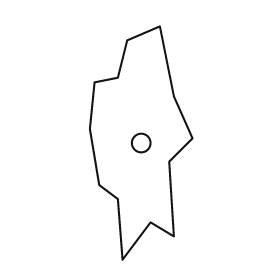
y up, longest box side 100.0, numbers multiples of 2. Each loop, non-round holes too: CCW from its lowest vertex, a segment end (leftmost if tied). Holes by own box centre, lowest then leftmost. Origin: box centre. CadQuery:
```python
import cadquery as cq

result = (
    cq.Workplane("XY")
    .moveTo(-8.0, -50.0)
    .lineTo(4.0, -34.0)
    .lineTo(14.0, -40.0)
    .lineTo(12.0, -8.0)
    .lineTo(22.0, 2.0)
    .lineTo(14.0, 20.0)
    .lineTo(8.0, 50.0)
    .lineTo(-6.0, 44.0)
    .lineTo(-10.0, 28.0)
    .lineTo(-20.0, 26.0)
    .lineTo(-22.0, 6.0)
    .lineTo(-18.0, -18.0)
    .lineTo(-10.0, -24.0)
    .close()
    .moveTo(0.0, 0.0)
    .circle(4.0)
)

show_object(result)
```